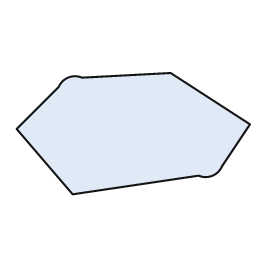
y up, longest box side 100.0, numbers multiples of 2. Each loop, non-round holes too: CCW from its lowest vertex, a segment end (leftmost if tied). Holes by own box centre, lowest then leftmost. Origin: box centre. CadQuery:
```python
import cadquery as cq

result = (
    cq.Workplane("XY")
    .moveTo(-26.0, -26.0)
    .lineTo(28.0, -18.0)
    .threePointArc((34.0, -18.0), (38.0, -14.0))
    .lineTo(50.0, 4.0)
    .lineTo(16.0, 26.0)
    .lineTo(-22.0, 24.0)
    .threePointArc((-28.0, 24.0), (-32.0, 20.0))
    .lineTo(-50.0, 2.0)
    .close()
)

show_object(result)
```